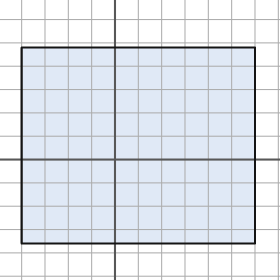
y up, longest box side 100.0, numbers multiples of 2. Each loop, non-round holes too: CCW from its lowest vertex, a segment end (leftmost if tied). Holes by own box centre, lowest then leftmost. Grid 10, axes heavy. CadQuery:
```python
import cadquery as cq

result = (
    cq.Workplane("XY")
    .moveTo(-40.0, -36.0)
    .lineTo(60.0, -36.0)
    .lineTo(60.0, 48.0)
    .lineTo(-40.0, 48.0)
    .close()
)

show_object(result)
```